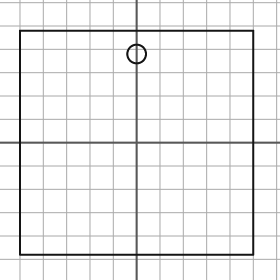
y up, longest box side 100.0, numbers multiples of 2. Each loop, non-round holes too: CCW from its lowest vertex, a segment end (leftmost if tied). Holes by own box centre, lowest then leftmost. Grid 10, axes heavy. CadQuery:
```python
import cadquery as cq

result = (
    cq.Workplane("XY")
    .moveTo(-50.0, -48.0)
    .lineTo(50.0, -48.0)
    .lineTo(50.0, 48.0)
    .lineTo(-50.0, 48.0)
    .close()
    .moveTo(0.0, 38.0)
    .circle(4.0)
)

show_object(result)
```